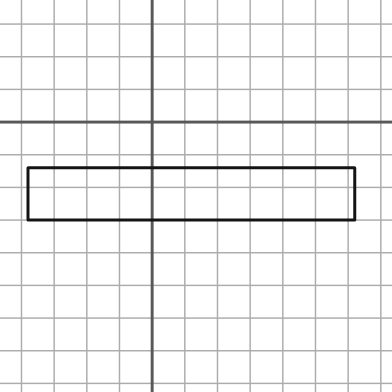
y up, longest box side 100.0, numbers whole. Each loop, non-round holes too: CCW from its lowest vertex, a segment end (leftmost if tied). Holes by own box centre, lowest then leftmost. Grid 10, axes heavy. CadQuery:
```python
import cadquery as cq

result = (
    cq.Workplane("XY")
    .moveTo(-38.0, -30.0)
    .lineTo(62.0, -30.0)
    .lineTo(62.0, -14.0)
    .lineTo(-38.0, -14.0)
    .close()
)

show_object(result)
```